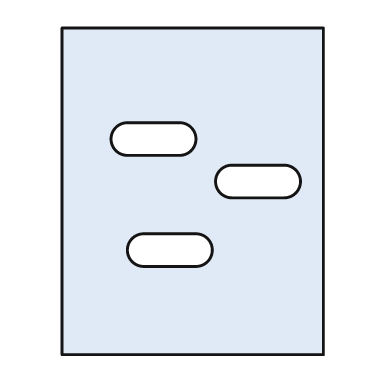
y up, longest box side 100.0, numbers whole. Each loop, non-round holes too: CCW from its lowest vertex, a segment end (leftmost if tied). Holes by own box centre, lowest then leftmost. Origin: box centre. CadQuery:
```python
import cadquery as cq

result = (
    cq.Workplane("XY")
    .moveTo(-40.0, -50.0)
    .lineTo(40.0, -50.0)
    .lineTo(40.0, 50.0)
    .lineTo(-40.0, 50.0)
    .close()
    .moveTo(-15.0, -23.0)
    .lineTo(1.0, -23.0)
    .threePointArc((6.0, -18.0), (1.0, -13.0))
    .lineTo(-15.0, -13.0)
    .threePointArc((-20.0, -18.0), (-15.0, -23.0))
    .close()
    .moveTo(12.0, -2.0)
    .lineTo(28.0, -2.0)
    .threePointArc((33.0, 3.0), (28.0, 8.0))
    .lineTo(12.0, 8.0)
    .threePointArc((7.0, 3.0), (12.0, -2.0))
    .close()
    .moveTo(-20.0, 11.0)
    .lineTo(-4.0, 11.0)
    .threePointArc((1.0, 16.0), (-4.0, 21.0))
    .lineTo(-20.0, 21.0)
    .threePointArc((-25.0, 16.0), (-20.0, 11.0))
    .close()
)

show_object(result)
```